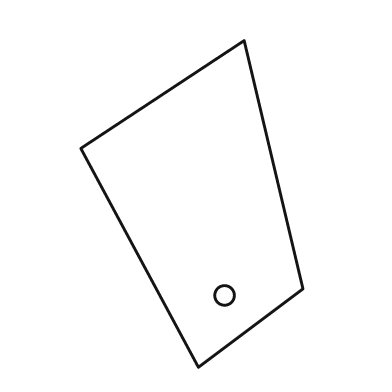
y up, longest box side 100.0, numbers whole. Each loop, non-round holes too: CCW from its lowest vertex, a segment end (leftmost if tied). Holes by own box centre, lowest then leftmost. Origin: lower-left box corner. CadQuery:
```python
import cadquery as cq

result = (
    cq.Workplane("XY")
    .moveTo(36.0, 0.0)
    .lineTo(68.0, 24.0)
    .lineTo(50.0, 100.0)
    .lineTo(0.0, 67.0)
    .close()
    .moveTo(44.0, 22.0)
    .circle(3.0)
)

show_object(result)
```